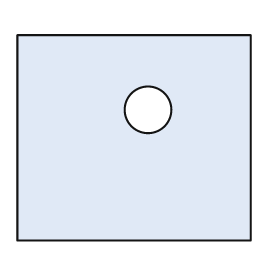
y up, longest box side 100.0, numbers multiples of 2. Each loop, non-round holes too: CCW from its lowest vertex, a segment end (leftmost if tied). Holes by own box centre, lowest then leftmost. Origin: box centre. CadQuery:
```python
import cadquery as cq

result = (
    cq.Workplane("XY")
    .moveTo(-50.0, -44.0)
    .lineTo(50.0, -44.0)
    .lineTo(50.0, 44.0)
    .lineTo(-50.0, 44.0)
    .close()
    .moveTo(6.0, 12.0)
    .circle(10.0)
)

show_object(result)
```